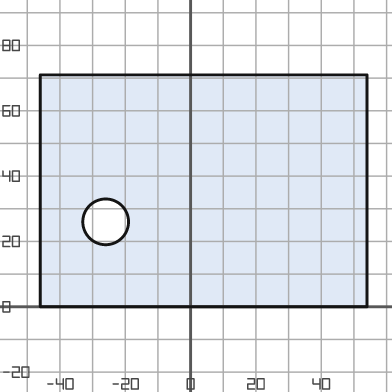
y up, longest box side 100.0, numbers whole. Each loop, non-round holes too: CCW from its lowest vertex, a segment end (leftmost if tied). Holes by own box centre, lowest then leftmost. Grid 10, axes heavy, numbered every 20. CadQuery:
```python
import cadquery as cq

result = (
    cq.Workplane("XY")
    .moveTo(-46.0, 0.0)
    .lineTo(54.0, 0.0)
    .lineTo(54.0, 71.0)
    .lineTo(-46.0, 71.0)
    .close()
    .moveTo(-26.0, 26.0)
    .circle(7.0)
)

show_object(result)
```